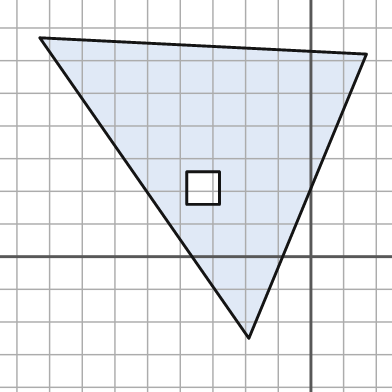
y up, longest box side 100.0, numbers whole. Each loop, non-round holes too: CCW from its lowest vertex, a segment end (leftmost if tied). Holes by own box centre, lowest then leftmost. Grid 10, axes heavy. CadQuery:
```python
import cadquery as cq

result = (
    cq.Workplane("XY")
    .moveTo(-19.0, -25.0)
    .lineTo(17.0, 62.0)
    .lineTo(-83.0, 67.0)
    .close()
    .moveTo(-38.0, 16.0)
    .lineTo(-28.0, 16.0)
    .lineTo(-28.0, 26.0)
    .lineTo(-38.0, 26.0)
    .close()
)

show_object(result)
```